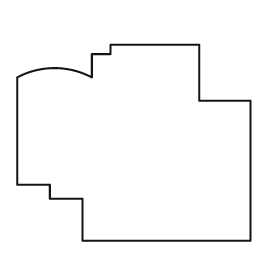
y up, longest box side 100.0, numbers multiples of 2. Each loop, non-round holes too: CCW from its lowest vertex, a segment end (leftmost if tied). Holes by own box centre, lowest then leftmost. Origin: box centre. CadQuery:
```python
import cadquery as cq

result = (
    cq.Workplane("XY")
    .moveTo(-22.0, -42.0)
    .lineTo(50.0, -42.0)
    .lineTo(50.0, 18.0)
    .lineTo(28.0, 18.0)
    .lineTo(28.0, 42.0)
    .lineTo(-10.0, 42.0)
    .lineTo(-10.0, 38.0)
    .lineTo(-18.0, 38.0)
    .lineTo(-18.0, 28.0)
    .threePointArc((-34.0, 32.0), (-50.0, 28.0))
    .lineTo(-50.0, -18.0)
    .lineTo(-36.0, -18.0)
    .lineTo(-36.0, -24.0)
    .lineTo(-22.0, -24.0)
    .close()
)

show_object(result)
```